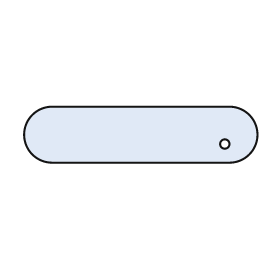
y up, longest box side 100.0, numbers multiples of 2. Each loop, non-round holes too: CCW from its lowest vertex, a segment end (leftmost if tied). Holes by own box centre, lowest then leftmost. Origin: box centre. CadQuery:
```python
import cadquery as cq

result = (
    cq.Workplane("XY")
    .moveTo(-38.0, -12.0)
    .lineTo(38.0, -12.0)
    .threePointArc((50.0, 0.0), (38.0, 12.0))
    .lineTo(-38.0, 12.0)
    .threePointArc((-50.0, 0.0), (-38.0, -12.0))
    .close()
    .moveTo(36.0, -4.0)
    .circle(2.0)
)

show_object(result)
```